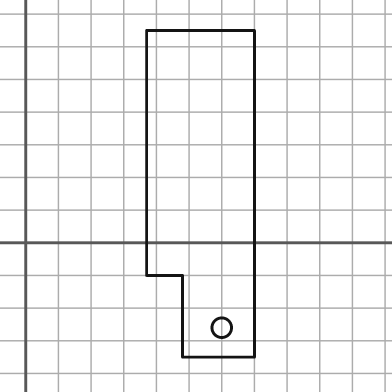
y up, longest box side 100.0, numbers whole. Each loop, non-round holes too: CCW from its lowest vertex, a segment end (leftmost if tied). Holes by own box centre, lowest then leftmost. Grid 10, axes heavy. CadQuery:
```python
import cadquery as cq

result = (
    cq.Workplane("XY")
    .moveTo(48.0, -35.0)
    .lineTo(70.0, -35.0)
    .lineTo(70.0, 65.0)
    .lineTo(37.0, 65.0)
    .lineTo(37.0, -10.0)
    .lineTo(48.0, -10.0)
    .close()
    .moveTo(60.0, -26.0)
    .circle(3.0)
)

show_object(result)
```